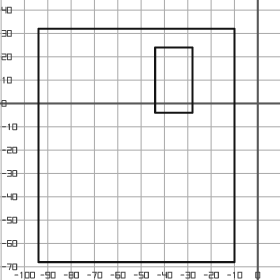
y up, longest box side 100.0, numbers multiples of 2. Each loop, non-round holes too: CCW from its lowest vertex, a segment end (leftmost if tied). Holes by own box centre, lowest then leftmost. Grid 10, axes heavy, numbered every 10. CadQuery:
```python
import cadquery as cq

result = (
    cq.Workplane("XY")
    .moveTo(-94.0, -68.0)
    .lineTo(-10.0, -68.0)
    .lineTo(-10.0, 32.0)
    .lineTo(-94.0, 32.0)
    .close()
    .moveTo(-44.0, -4.0)
    .lineTo(-28.0, -4.0)
    .lineTo(-28.0, 24.0)
    .lineTo(-44.0, 24.0)
    .close()
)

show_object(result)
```